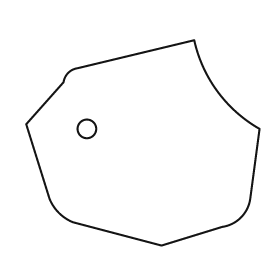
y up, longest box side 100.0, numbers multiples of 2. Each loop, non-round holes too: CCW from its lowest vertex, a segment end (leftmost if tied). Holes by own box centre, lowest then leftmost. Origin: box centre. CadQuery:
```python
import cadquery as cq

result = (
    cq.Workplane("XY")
    .moveTo(8.0, -44.0)
    .lineTo(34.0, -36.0)
    .threePointArc((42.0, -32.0), (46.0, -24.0))
    .lineTo(50.0, 6.0)
    .threePointArc((32.0, 22.0), (22.0, 44.0))
    .lineTo(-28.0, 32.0)
    .threePointArc((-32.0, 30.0), (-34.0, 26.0))
    .lineTo(-50.0, 8.0)
    .lineTo(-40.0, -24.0)
    .threePointArc((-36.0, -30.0), (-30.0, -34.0))
    .close()
    .moveTo(-24.0, 6.0)
    .circle(4.0)
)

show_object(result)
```